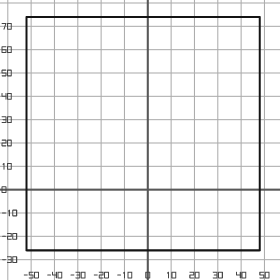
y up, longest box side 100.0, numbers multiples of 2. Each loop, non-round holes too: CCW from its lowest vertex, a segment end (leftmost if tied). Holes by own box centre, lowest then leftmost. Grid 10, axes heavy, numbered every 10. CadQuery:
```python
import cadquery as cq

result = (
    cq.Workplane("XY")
    .moveTo(-52.0, -26.0)
    .lineTo(48.0, -26.0)
    .lineTo(48.0, 74.0)
    .lineTo(-52.0, 74.0)
    .close()
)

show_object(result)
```